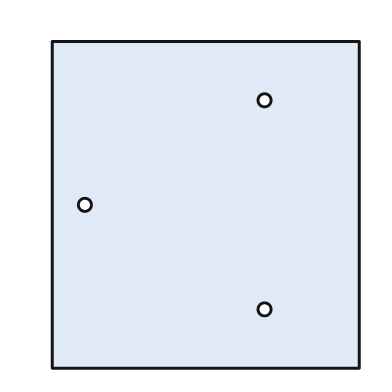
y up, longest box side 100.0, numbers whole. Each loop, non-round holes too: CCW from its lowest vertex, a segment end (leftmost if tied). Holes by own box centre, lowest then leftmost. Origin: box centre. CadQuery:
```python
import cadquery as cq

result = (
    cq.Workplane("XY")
    .moveTo(-47.0, -50.0)
    .lineTo(47.0, -50.0)
    .lineTo(47.0, 50.0)
    .lineTo(-47.0, 50.0)
    .close()
    .moveTo(18.0, -32.0)
    .circle(2.0)
    .moveTo(-37.0, 0.0)
    .circle(2.0)
    .moveTo(18.0, 32.0)
    .circle(2.0)
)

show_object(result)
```